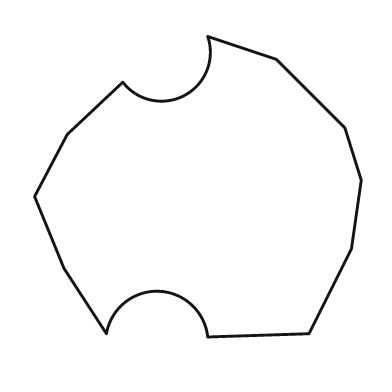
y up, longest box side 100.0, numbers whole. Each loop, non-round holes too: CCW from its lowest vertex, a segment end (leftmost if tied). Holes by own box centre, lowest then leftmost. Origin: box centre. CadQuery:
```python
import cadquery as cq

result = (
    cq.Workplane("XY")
    .moveTo(3.0, -46.0)
    .lineTo(34.0, -45.0)
    .lineTo(47.0, -19.0)
    .lineTo(50.0, 2.0)
    .lineTo(45.0, 18.0)
    .lineTo(24.0, 39.0)
    .lineTo(3.0, 46.0)
    .threePointArc((-4.0, 28.0), (-23.0, 32.0))
    .lineTo(-40.0, 16.0)
    .lineTo(-50.0, -3.0)
    .lineTo(-41.0, -25.0)
    .lineTo(-28.0, -45.0)
    .threePointArc((-12.0, -32.0), (3.0, -46.0))
    .close()
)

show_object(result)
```